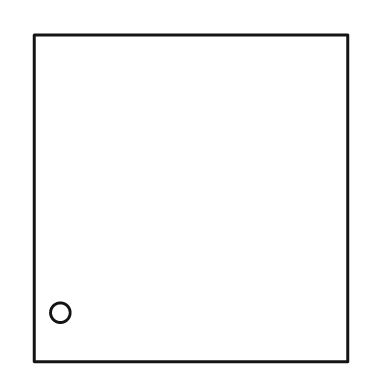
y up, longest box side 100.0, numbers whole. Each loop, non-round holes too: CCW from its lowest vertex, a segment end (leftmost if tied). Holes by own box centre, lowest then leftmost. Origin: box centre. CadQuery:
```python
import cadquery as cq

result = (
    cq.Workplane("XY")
    .moveTo(-48.0, -50.0)
    .lineTo(48.0, -50.0)
    .lineTo(48.0, 50.0)
    .lineTo(-48.0, 50.0)
    .close()
    .moveTo(-40.0, -35.0)
    .circle(3.0)
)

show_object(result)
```